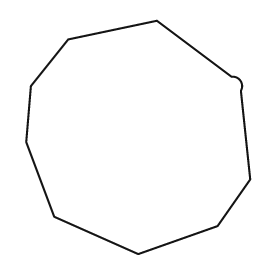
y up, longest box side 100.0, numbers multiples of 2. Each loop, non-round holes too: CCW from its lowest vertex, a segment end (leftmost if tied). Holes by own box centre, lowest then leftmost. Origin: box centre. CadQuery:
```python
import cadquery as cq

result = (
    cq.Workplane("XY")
    .moveTo(0.0, -50.0)
    .lineTo(34.0, -38.0)
    .lineTo(48.0, -18.0)
    .lineTo(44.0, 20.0)
    .threePointArc((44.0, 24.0), (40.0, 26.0))
    .lineTo(8.0, 50.0)
    .lineTo(-30.0, 42.0)
    .lineTo(-46.0, 22.0)
    .lineTo(-48.0, -2.0)
    .lineTo(-36.0, -34.0)
    .close()
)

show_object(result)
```